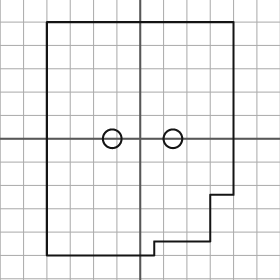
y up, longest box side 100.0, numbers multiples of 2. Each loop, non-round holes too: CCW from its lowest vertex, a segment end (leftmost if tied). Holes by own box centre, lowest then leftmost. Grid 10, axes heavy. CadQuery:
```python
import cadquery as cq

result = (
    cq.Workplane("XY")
    .moveTo(-40.0, -50.0)
    .lineTo(6.0, -50.0)
    .lineTo(6.0, -44.0)
    .lineTo(30.0, -44.0)
    .lineTo(30.0, -24.0)
    .lineTo(40.0, -24.0)
    .lineTo(40.0, 50.0)
    .lineTo(-40.0, 50.0)
    .close()
    .moveTo(-12.0, 0.0)
    .circle(4.0)
    .moveTo(14.0, 0.0)
    .circle(4.0)
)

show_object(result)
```